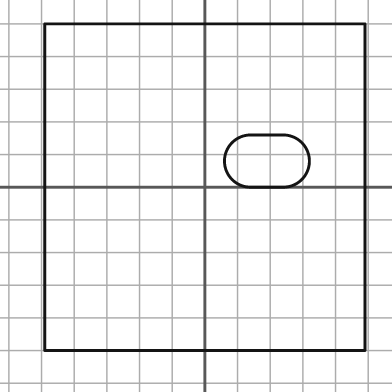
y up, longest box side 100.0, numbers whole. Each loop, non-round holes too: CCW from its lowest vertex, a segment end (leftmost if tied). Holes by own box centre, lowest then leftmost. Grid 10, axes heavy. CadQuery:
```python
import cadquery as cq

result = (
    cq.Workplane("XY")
    .moveTo(-49.0, -50.0)
    .lineTo(49.0, -50.0)
    .lineTo(49.0, 50.0)
    .lineTo(-49.0, 50.0)
    .close()
    .moveTo(14.0, 0.0)
    .lineTo(24.0, 0.0)
    .threePointArc((32.0, 8.0), (24.0, 16.0))
    .lineTo(14.0, 16.0)
    .threePointArc((6.0, 8.0), (14.0, 0.0))
    .close()
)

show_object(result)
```